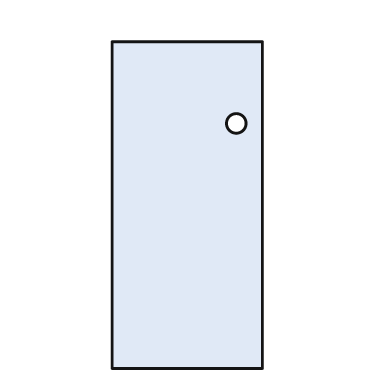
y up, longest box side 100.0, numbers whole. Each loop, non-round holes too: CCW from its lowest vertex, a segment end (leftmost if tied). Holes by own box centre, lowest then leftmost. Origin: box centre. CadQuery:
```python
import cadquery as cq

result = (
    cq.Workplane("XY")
    .moveTo(-23.0, -50.0)
    .lineTo(23.0, -50.0)
    .lineTo(23.0, 50.0)
    .lineTo(-23.0, 50.0)
    .close()
    .moveTo(15.0, 25.0)
    .circle(3.0)
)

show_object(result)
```